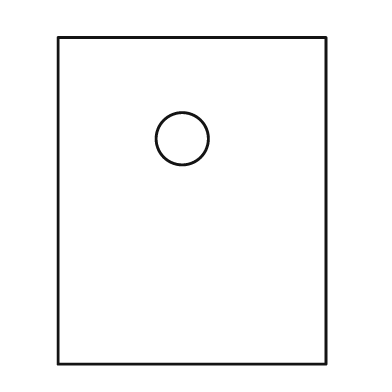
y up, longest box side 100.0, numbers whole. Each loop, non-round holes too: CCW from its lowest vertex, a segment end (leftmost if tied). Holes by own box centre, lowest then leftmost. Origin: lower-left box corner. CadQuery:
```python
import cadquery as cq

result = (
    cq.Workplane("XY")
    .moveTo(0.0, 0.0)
    .lineTo(82.0, 0.0)
    .lineTo(82.0, 100.0)
    .lineTo(0.0, 100.0)
    .close()
    .moveTo(38.0, 69.0)
    .circle(8.0)
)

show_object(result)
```